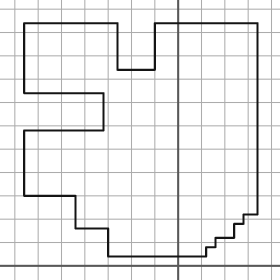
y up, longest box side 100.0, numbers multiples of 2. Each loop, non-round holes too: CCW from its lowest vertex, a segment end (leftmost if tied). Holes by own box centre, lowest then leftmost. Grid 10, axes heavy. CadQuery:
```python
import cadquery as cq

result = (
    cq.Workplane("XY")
    .moveTo(-30.0, 4.0)
    .lineTo(12.0, 4.0)
    .lineTo(12.0, 8.0)
    .lineTo(16.0, 8.0)
    .lineTo(16.0, 12.0)
    .lineTo(24.0, 12.0)
    .lineTo(24.0, 18.0)
    .lineTo(28.0, 18.0)
    .lineTo(28.0, 22.0)
    .lineTo(34.0, 22.0)
    .lineTo(34.0, 104.0)
    .lineTo(-10.0, 104.0)
    .lineTo(-10.0, 84.0)
    .lineTo(-26.0, 84.0)
    .lineTo(-26.0, 104.0)
    .lineTo(-66.0, 104.0)
    .lineTo(-66.0, 74.0)
    .lineTo(-32.0, 74.0)
    .lineTo(-32.0, 58.0)
    .lineTo(-66.0, 58.0)
    .lineTo(-66.0, 30.0)
    .lineTo(-44.0, 30.0)
    .lineTo(-44.0, 16.0)
    .lineTo(-30.0, 16.0)
    .close()
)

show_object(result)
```